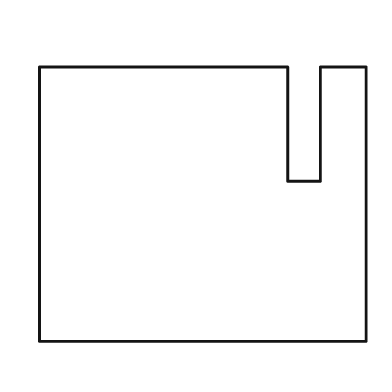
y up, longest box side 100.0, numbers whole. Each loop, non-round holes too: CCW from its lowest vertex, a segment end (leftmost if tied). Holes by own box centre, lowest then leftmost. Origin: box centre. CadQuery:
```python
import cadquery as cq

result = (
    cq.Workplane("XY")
    .moveTo(-50.0, -42.0)
    .lineTo(50.0, -42.0)
    .lineTo(50.0, 42.0)
    .lineTo(36.0, 42.0)
    .lineTo(36.0, 7.0)
    .lineTo(26.0, 7.0)
    .lineTo(26.0, 42.0)
    .lineTo(-50.0, 42.0)
    .close()
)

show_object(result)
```